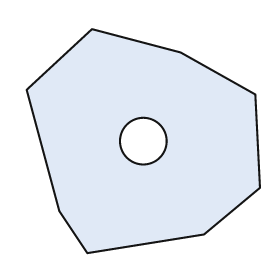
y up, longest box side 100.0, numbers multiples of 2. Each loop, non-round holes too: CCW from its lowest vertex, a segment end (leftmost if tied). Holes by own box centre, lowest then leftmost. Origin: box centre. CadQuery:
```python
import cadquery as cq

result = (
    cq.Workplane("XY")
    .moveTo(-24.0, -48.0)
    .lineTo(26.0, -40.0)
    .lineTo(50.0, -20.0)
    .lineTo(48.0, 20.0)
    .lineTo(16.0, 38.0)
    .lineTo(-22.0, 48.0)
    .lineTo(-50.0, 22.0)
    .lineTo(-36.0, -30.0)
    .close()
    .moveTo(0.0, 0.0)
    .circle(10.0)
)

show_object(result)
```